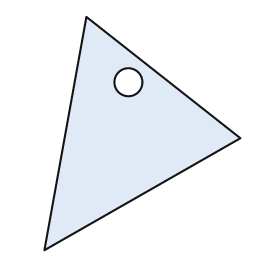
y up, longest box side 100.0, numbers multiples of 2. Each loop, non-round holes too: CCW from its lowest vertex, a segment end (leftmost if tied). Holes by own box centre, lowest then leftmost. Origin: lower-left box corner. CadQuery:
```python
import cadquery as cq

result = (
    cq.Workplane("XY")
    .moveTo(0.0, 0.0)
    .lineTo(84.0, 48.0)
    .lineTo(18.0, 100.0)
    .close()
    .moveTo(36.0, 72.0)
    .circle(6.0)
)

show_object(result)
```